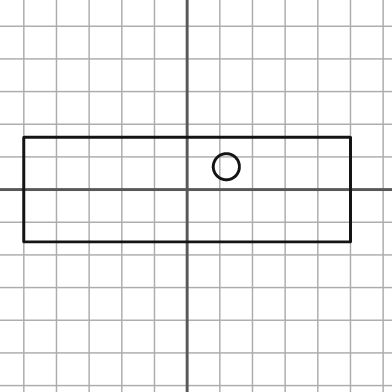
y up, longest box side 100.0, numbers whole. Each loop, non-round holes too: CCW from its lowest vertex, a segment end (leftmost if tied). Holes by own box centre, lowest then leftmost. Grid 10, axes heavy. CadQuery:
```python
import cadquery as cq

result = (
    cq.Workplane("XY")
    .moveTo(-50.0, -16.0)
    .lineTo(50.0, -16.0)
    .lineTo(50.0, 16.0)
    .lineTo(-50.0, 16.0)
    .close()
    .moveTo(12.0, 7.0)
    .circle(4.0)
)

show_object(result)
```